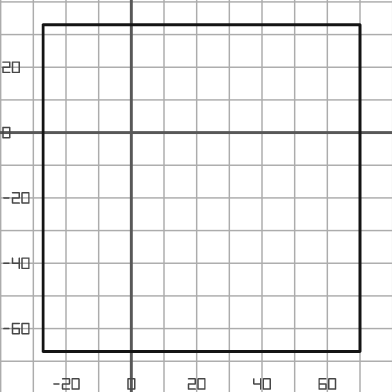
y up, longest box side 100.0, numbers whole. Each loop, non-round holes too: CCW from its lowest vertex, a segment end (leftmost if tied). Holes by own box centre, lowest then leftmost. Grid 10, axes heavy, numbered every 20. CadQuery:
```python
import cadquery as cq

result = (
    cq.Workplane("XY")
    .moveTo(-27.0, -67.0)
    .lineTo(70.0, -67.0)
    .lineTo(70.0, 33.0)
    .lineTo(-27.0, 33.0)
    .close()
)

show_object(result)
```